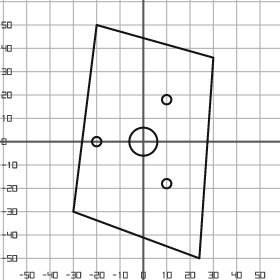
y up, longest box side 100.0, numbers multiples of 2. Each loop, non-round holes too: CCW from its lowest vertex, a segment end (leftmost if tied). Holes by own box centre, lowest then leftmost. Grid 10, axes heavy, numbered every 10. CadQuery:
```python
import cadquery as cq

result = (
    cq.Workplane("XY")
    .moveTo(24.0, -50.0)
    .lineTo(30.0, 36.0)
    .lineTo(-20.0, 50.0)
    .lineTo(-30.0, -30.0)
    .close()
    .moveTo(10.0, -18.0)
    .circle(2.0)
    .moveTo(-20.0, 0.0)
    .circle(2.0)
    .moveTo(0.0, 0.0)
    .circle(6.0)
    .moveTo(10.0, 18.0)
    .circle(2.0)
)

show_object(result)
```